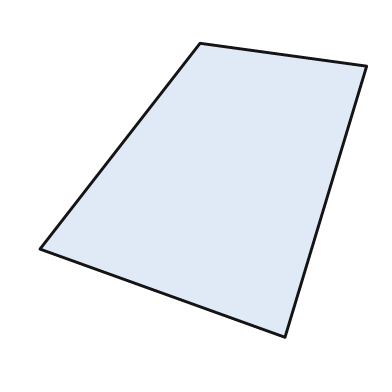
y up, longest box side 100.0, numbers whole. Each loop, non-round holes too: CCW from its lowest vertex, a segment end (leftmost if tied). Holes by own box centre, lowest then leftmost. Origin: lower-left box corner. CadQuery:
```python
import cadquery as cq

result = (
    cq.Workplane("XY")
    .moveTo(75.0, 0.0)
    .lineTo(100.0, 83.0)
    .lineTo(49.0, 90.0)
    .lineTo(0.0, 27.0)
    .close()
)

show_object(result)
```